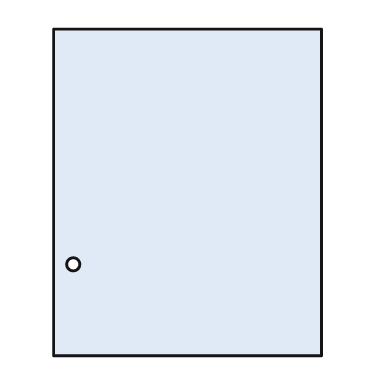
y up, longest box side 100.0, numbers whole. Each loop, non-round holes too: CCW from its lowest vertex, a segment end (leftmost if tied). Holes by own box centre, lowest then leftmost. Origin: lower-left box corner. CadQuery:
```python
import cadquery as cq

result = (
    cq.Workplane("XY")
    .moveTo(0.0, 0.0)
    .lineTo(82.0, 0.0)
    .lineTo(82.0, 100.0)
    .lineTo(0.0, 100.0)
    .close()
    .moveTo(6.0, 28.0)
    .circle(2.0)
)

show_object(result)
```